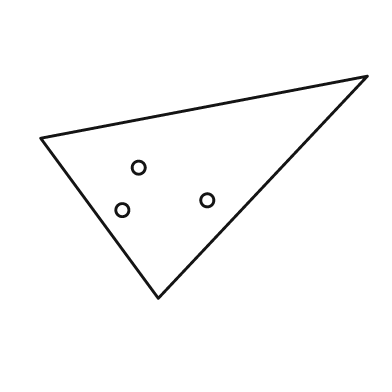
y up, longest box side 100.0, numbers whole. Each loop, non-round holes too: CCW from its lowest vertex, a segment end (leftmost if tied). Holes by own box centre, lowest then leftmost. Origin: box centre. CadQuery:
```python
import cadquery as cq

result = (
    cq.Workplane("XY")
    .moveTo(-14.0, -34.0)
    .lineTo(50.0, 34.0)
    .lineTo(-50.0, 15.0)
    .close()
    .moveTo(-25.0, -7.0)
    .circle(2.0)
    .moveTo(1.0, -4.0)
    .circle(2.0)
    .moveTo(-20.0, 6.0)
    .circle(2.0)
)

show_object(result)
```